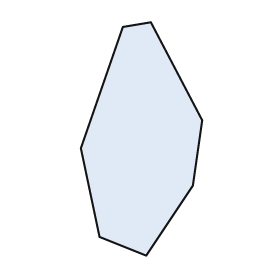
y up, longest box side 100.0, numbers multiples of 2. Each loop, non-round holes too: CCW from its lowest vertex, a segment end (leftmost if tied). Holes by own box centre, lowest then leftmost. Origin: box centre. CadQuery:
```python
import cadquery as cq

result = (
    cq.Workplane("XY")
    .moveTo(2.0, -50.0)
    .lineTo(22.0, -20.0)
    .lineTo(26.0, 8.0)
    .lineTo(4.0, 50.0)
    .lineTo(-8.0, 48.0)
    .lineTo(-26.0, -4.0)
    .lineTo(-18.0, -42.0)
    .close()
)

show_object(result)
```